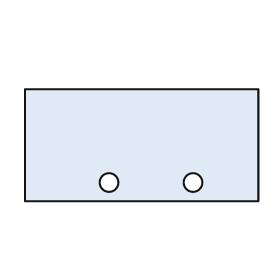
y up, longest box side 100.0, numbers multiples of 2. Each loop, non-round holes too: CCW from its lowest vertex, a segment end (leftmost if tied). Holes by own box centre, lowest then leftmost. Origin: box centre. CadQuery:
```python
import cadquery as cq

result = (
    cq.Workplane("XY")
    .moveTo(-50.0, -24.0)
    .lineTo(50.0, -24.0)
    .lineTo(50.0, 24.0)
    .lineTo(-50.0, 24.0)
    .close()
    .moveTo(-14.0, -16.0)
    .circle(4.0)
    .moveTo(22.0, -16.0)
    .circle(4.0)
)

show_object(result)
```